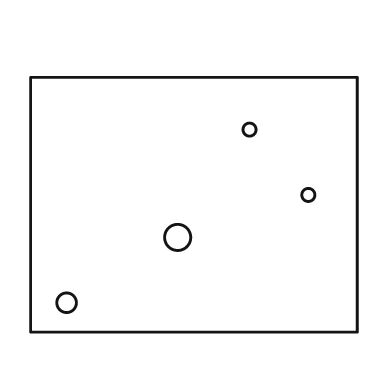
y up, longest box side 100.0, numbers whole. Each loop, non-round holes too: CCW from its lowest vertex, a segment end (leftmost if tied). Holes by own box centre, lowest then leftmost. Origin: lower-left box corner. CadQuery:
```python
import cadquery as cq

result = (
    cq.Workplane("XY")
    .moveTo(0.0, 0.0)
    .lineTo(100.0, 0.0)
    .lineTo(100.0, 78.0)
    .lineTo(0.0, 78.0)
    .close()
    .moveTo(11.0, 9.0)
    .circle(3.0)
    .moveTo(45.0, 29.0)
    .circle(4.0)
    .moveTo(85.0, 42.0)
    .circle(2.0)
    .moveTo(67.0, 62.0)
    .circle(2.0)
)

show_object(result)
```